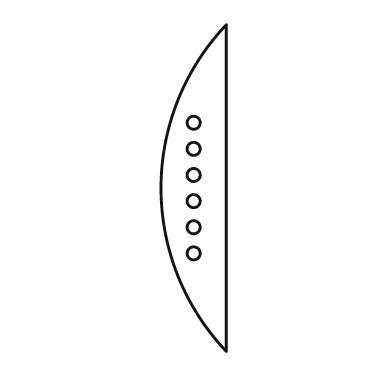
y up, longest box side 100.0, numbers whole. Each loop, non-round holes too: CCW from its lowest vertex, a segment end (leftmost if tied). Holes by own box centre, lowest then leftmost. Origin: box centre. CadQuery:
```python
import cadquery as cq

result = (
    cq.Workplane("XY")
    .moveTo(10.0, -50.0)
    .lineTo(10.0, 50.0)
    .threePointArc((-10.0, 0.0), (10.0, -50.0))
    .close()
    .moveTo(0.0, -20.0)
    .circle(2.0)
    .moveTo(0.0, -12.0)
    .circle(2.0)
    .moveTo(0.0, -4.0)
    .circle(2.0)
    .moveTo(0.0, 4.0)
    .circle(2.0)
    .moveTo(0.0, 12.0)
    .circle(2.0)
    .moveTo(0.0, 20.0)
    .circle(2.0)
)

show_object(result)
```